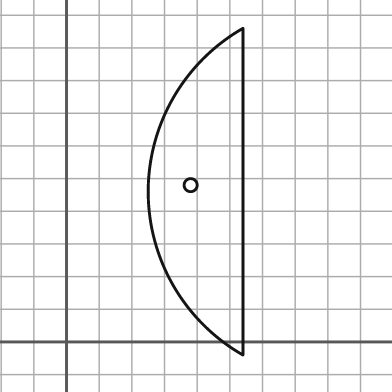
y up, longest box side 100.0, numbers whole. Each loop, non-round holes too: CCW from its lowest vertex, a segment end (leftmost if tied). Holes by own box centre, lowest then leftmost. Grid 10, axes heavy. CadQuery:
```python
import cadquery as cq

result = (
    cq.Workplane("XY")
    .moveTo(54.0, -4.0)
    .lineTo(54.0, 96.0)
    .threePointArc((25.0, 46.0), (54.0, -4.0))
    .close()
    .moveTo(38.0, 48.0)
    .circle(2.0)
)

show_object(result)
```